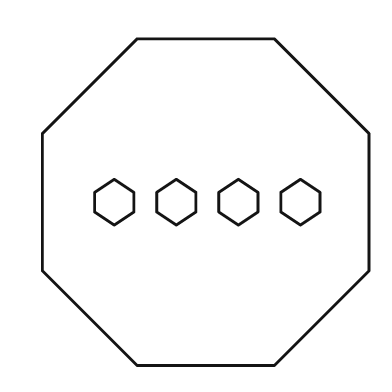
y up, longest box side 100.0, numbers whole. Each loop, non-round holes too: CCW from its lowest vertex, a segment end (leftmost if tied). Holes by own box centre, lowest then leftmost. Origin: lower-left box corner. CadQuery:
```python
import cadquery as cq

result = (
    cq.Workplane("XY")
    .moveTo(29.0, 0.0)
    .lineTo(71.0, 0.0)
    .lineTo(100.0, 29.0)
    .lineTo(100.0, 71.0)
    .lineTo(71.0, 100.0)
    .lineTo(29.0, 100.0)
    .lineTo(0.0, 71.0)
    .lineTo(0.0, 29.0)
    .close()
    .moveTo(22.0, 43.0)
    .lineTo(28.0, 47.0)
    .lineTo(28.0, 53.0)
    .lineTo(22.0, 57.0)
    .lineTo(16.0, 53.0)
    .lineTo(16.0, 47.0)
    .close()
    .moveTo(41.0, 43.0)
    .lineTo(47.0, 47.0)
    .lineTo(47.0, 53.0)
    .lineTo(41.0, 57.0)
    .lineTo(35.0, 53.0)
    .lineTo(35.0, 47.0)
    .close()
    .moveTo(60.0, 43.0)
    .lineTo(66.0, 47.0)
    .lineTo(66.0, 53.0)
    .lineTo(60.0, 57.0)
    .lineTo(54.0, 53.0)
    .lineTo(54.0, 47.0)
    .close()
    .moveTo(79.0, 43.0)
    .lineTo(85.0, 47.0)
    .lineTo(85.0, 53.0)
    .lineTo(79.0, 57.0)
    .lineTo(73.0, 53.0)
    .lineTo(73.0, 47.0)
    .close()
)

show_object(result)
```